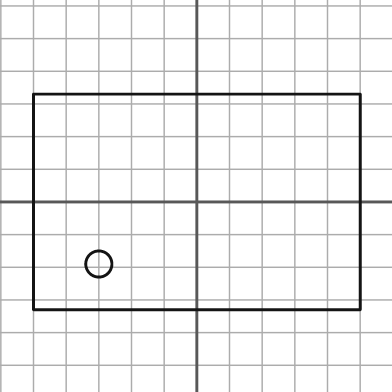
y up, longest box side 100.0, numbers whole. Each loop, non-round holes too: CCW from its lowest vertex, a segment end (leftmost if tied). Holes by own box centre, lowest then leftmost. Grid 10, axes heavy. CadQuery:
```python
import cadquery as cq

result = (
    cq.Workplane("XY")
    .moveTo(-50.0, -33.0)
    .lineTo(50.0, -33.0)
    .lineTo(50.0, 33.0)
    .lineTo(-50.0, 33.0)
    .close()
    .moveTo(-30.0, -19.0)
    .circle(4.0)
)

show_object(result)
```